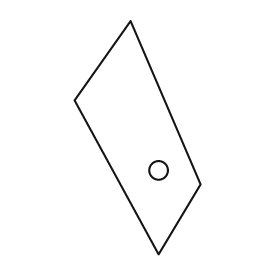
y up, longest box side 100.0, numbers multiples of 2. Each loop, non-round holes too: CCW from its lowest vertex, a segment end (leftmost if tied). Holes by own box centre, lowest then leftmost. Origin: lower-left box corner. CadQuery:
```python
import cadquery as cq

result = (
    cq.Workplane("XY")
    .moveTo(36.0, 0.0)
    .lineTo(54.0, 30.0)
    .lineTo(24.0, 100.0)
    .lineTo(0.0, 66.0)
    .close()
    .moveTo(36.0, 36.0)
    .circle(4.0)
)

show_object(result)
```